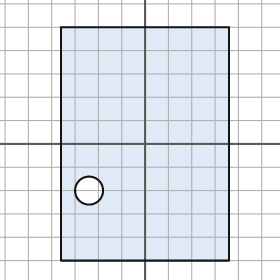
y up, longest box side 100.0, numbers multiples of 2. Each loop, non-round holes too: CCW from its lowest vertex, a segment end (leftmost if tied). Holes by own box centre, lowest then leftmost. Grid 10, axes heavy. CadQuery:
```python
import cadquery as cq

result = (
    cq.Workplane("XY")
    .moveTo(-36.0, -50.0)
    .lineTo(36.0, -50.0)
    .lineTo(36.0, 50.0)
    .lineTo(-36.0, 50.0)
    .close()
    .moveTo(-24.0, -20.0)
    .circle(6.0)
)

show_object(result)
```